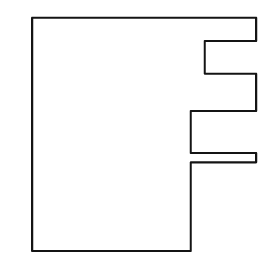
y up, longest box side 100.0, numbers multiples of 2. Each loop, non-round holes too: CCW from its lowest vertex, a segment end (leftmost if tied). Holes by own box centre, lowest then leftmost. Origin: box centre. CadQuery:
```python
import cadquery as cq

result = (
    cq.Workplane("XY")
    .moveTo(-48.0, -50.0)
    .lineTo(20.0, -50.0)
    .lineTo(20.0, -12.0)
    .lineTo(48.0, -12.0)
    .lineTo(48.0, -8.0)
    .lineTo(20.0, -8.0)
    .lineTo(20.0, 10.0)
    .lineTo(48.0, 10.0)
    .lineTo(48.0, 26.0)
    .lineTo(26.0, 26.0)
    .lineTo(26.0, 40.0)
    .lineTo(48.0, 40.0)
    .lineTo(48.0, 50.0)
    .lineTo(-48.0, 50.0)
    .close()
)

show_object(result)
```